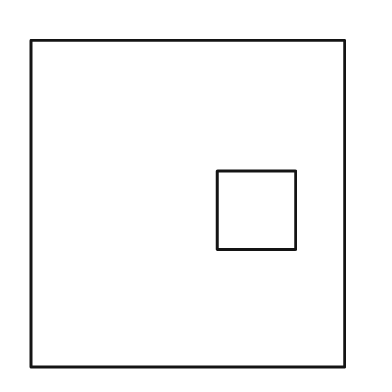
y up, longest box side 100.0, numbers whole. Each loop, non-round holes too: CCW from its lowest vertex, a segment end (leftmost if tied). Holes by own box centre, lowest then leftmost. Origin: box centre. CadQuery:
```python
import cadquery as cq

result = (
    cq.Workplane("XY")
    .moveTo(-48.0, -50.0)
    .lineTo(48.0, -50.0)
    .lineTo(48.0, 50.0)
    .lineTo(-48.0, 50.0)
    .close()
    .moveTo(9.0, -14.0)
    .lineTo(33.0, -14.0)
    .lineTo(33.0, 10.0)
    .lineTo(9.0, 10.0)
    .close()
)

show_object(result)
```